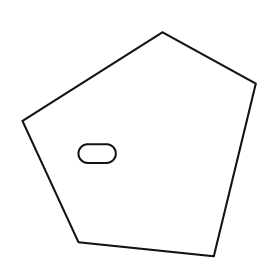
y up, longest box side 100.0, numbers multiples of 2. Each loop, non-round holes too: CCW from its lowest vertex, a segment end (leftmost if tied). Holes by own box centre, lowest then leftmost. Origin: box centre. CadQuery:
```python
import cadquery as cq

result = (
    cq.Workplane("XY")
    .moveTo(32.0, -48.0)
    .lineTo(50.0, 26.0)
    .lineTo(10.0, 48.0)
    .lineTo(-50.0, 10.0)
    .lineTo(-26.0, -42.0)
    .close()
    .moveTo(-22.0, -8.0)
    .lineTo(-14.0, -8.0)
    .threePointArc((-10.0, -4.0), (-14.0, 0.0))
    .lineTo(-22.0, 0.0)
    .threePointArc((-26.0, -4.0), (-22.0, -8.0))
    .close()
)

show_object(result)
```